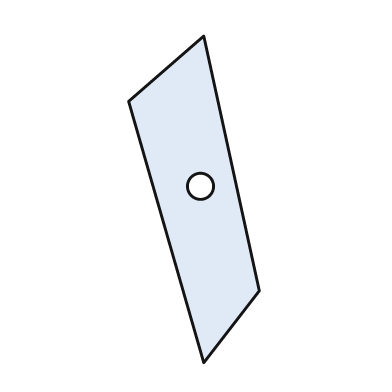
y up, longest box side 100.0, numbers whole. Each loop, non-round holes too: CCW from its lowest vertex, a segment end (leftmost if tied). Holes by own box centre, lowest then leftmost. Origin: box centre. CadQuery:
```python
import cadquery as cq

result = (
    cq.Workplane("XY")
    .moveTo(3.0, -50.0)
    .lineTo(20.0, -28.0)
    .lineTo(3.0, 50.0)
    .lineTo(-20.0, 30.0)
    .close()
    .moveTo(2.0, 4.0)
    .circle(4.0)
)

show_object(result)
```